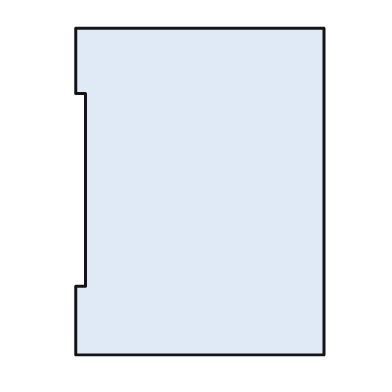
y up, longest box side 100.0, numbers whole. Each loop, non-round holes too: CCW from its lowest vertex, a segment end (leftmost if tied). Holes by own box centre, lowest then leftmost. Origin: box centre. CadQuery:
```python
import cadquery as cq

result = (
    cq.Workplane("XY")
    .moveTo(-38.0, -50.0)
    .lineTo(38.0, -50.0)
    .lineTo(38.0, 50.0)
    .lineTo(-38.0, 50.0)
    .lineTo(-38.0, 30.0)
    .lineTo(-35.0, 30.0)
    .lineTo(-35.0, -29.0)
    .lineTo(-38.0, -29.0)
    .close()
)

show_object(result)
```